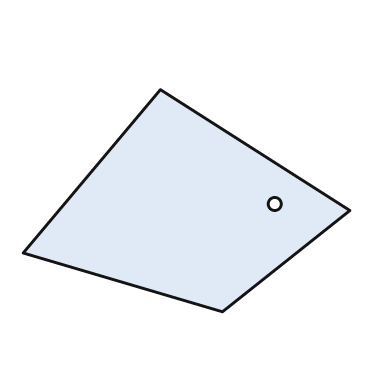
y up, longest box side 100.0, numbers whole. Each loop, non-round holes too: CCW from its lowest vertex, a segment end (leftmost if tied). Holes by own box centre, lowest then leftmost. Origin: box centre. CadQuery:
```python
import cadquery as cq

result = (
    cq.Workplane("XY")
    .moveTo(11.0, -34.0)
    .lineTo(50.0, -3.0)
    .lineTo(-8.0, 34.0)
    .lineTo(-50.0, -16.0)
    .close()
    .moveTo(27.0, -1.0)
    .circle(2.0)
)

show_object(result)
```